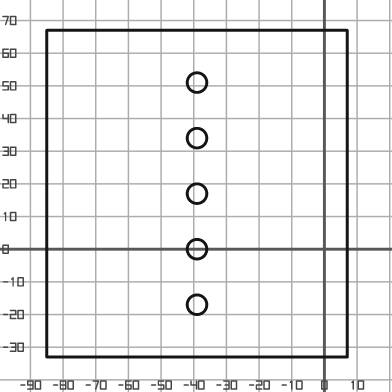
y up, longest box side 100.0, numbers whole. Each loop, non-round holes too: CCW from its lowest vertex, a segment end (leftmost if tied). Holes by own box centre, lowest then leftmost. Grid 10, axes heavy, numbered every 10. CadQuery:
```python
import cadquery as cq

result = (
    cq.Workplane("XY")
    .moveTo(-85.0, -33.0)
    .lineTo(7.0, -33.0)
    .lineTo(7.0, 67.0)
    .lineTo(-85.0, 67.0)
    .close()
    .moveTo(-39.0, -17.0)
    .circle(3.0)
    .moveTo(-39.0, 0.0)
    .circle(3.0)
    .moveTo(-39.0, 17.0)
    .circle(3.0)
    .moveTo(-39.0, 34.0)
    .circle(3.0)
    .moveTo(-39.0, 51.0)
    .circle(3.0)
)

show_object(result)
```